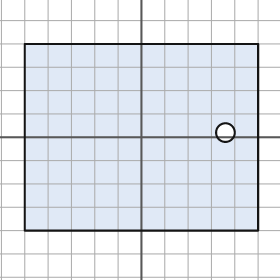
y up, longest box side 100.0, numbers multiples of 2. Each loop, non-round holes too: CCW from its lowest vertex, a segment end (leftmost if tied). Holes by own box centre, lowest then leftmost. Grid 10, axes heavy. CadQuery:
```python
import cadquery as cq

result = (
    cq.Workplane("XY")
    .moveTo(-50.0, -40.0)
    .lineTo(50.0, -40.0)
    .lineTo(50.0, 40.0)
    .lineTo(-50.0, 40.0)
    .close()
    .moveTo(36.0, 2.0)
    .circle(4.0)
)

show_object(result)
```